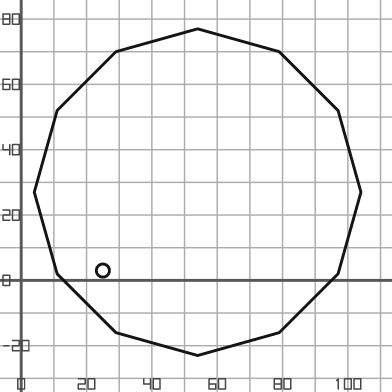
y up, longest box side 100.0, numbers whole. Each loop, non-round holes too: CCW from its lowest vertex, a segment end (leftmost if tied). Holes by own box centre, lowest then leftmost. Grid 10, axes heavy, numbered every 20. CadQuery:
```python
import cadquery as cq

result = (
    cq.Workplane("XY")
    .moveTo(54.0, -23.0)
    .lineTo(79.0, -16.0)
    .lineTo(97.0, 2.0)
    .lineTo(104.0, 27.0)
    .lineTo(97.0, 52.0)
    .lineTo(79.0, 70.0)
    .lineTo(54.0, 77.0)
    .lineTo(29.0, 70.0)
    .lineTo(11.0, 52.0)
    .lineTo(4.0, 27.0)
    .lineTo(11.0, 2.0)
    .lineTo(29.0, -16.0)
    .close()
    .moveTo(25.0, 3.0)
    .circle(2.0)
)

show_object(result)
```